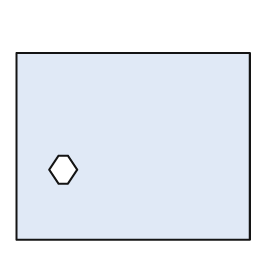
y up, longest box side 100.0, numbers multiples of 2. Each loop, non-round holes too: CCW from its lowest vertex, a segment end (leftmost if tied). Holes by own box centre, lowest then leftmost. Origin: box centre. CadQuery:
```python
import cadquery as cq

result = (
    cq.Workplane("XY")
    .moveTo(-50.0, -40.0)
    .lineTo(50.0, -40.0)
    .lineTo(50.0, 40.0)
    .lineTo(-50.0, 40.0)
    .close()
    .moveTo(-32.0, -16.0)
    .lineTo(-28.0, -16.0)
    .lineTo(-24.0, -10.0)
    .lineTo(-28.0, -4.0)
    .lineTo(-32.0, -4.0)
    .lineTo(-36.0, -10.0)
    .close()
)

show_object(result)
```